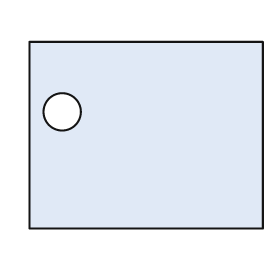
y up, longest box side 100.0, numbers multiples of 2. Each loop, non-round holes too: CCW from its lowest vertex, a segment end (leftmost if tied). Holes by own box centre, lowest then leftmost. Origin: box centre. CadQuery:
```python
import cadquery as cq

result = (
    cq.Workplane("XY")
    .moveTo(-50.0, -40.0)
    .lineTo(50.0, -40.0)
    .lineTo(50.0, 40.0)
    .lineTo(-50.0, 40.0)
    .close()
    .moveTo(-36.0, 10.0)
    .circle(8.0)
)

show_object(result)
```